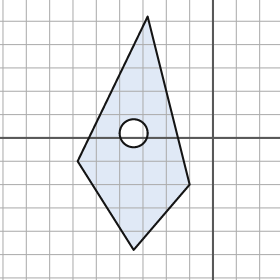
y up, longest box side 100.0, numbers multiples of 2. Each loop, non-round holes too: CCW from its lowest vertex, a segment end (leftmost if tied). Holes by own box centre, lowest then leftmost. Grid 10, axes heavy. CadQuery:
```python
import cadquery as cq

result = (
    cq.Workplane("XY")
    .moveTo(-34.0, -48.0)
    .lineTo(-10.0, -20.0)
    .lineTo(-28.0, 52.0)
    .lineTo(-58.0, -10.0)
    .close()
    .moveTo(-34.0, 2.0)
    .circle(6.0)
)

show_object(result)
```